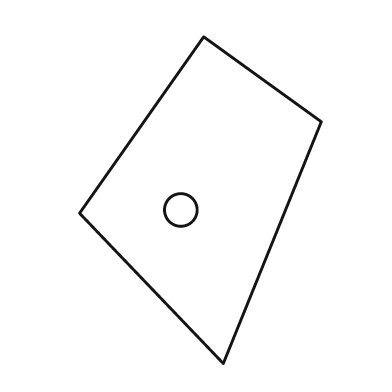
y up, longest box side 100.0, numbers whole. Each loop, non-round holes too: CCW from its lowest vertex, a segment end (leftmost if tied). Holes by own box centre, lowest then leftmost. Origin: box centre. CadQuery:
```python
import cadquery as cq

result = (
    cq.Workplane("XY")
    .moveTo(7.0, -50.0)
    .lineTo(37.0, 24.0)
    .lineTo(1.0, 50.0)
    .lineTo(-37.0, -4.0)
    .close()
    .moveTo(-6.0, -3.0)
    .circle(5.0)
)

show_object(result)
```